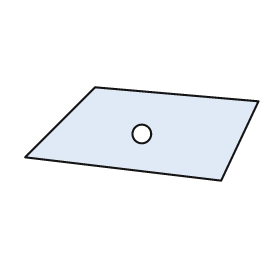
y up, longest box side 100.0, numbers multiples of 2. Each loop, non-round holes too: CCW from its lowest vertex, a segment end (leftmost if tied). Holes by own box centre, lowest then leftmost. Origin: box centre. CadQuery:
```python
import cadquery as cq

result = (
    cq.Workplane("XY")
    .moveTo(34.0, -20.0)
    .lineTo(50.0, 14.0)
    .lineTo(-20.0, 20.0)
    .lineTo(-50.0, -10.0)
    .close()
    .moveTo(0.0, 0.0)
    .circle(4.0)
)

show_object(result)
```